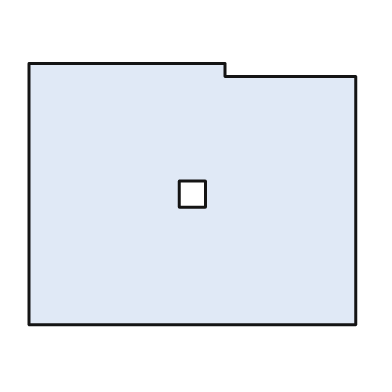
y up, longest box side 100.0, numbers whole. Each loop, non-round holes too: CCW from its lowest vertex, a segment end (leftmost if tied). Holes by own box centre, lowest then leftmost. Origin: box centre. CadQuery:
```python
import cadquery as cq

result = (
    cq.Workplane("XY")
    .moveTo(-50.0, -40.0)
    .lineTo(50.0, -40.0)
    .lineTo(50.0, 36.0)
    .lineTo(10.0, 36.0)
    .lineTo(10.0, 40.0)
    .lineTo(-50.0, 40.0)
    .close()
    .moveTo(-4.0, -4.0)
    .lineTo(4.0, -4.0)
    .lineTo(4.0, 4.0)
    .lineTo(-4.0, 4.0)
    .close()
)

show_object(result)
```